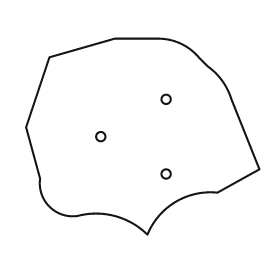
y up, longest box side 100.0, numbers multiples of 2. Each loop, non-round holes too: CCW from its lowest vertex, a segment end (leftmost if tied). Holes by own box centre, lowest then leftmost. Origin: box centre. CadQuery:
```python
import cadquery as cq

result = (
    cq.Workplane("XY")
    .moveTo(2.0, -42.0)
    .threePointArc((14.0, -28.0), (32.0, -24.0))
    .lineTo(50.0, -14.0)
    .lineTo(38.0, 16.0)
    .threePointArc((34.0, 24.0), (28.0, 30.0))
    .lineTo(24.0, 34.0)
    .threePointArc((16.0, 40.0), (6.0, 42.0))
    .lineTo(-12.0, 42.0)
    .lineTo(-40.0, 34.0)
    .lineTo(-50.0, 4.0)
    .lineTo(-44.0, -18.0)
    .threePointArc((-40.0, -30.0), (-28.0, -34.0))
    .threePointArc((-12.0, -34.0), (2.0, -42.0))
    .close()
    .moveTo(10.0, -16.0)
    .circle(2.0)
    .moveTo(-18.0, 0.0)
    .circle(2.0)
    .moveTo(10.0, 16.0)
    .circle(2.0)
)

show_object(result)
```